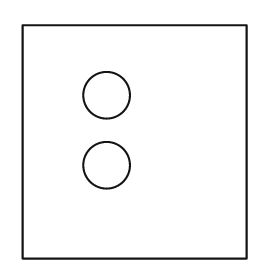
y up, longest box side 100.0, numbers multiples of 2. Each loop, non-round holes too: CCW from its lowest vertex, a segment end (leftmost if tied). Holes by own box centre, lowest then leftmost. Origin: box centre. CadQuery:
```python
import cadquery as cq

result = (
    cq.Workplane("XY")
    .moveTo(-48.0, -50.0)
    .lineTo(48.0, -50.0)
    .lineTo(48.0, 50.0)
    .lineTo(-48.0, 50.0)
    .close()
    .moveTo(-12.0, -10.0)
    .circle(10.0)
    .moveTo(-12.0, 20.0)
    .circle(10.0)
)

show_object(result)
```